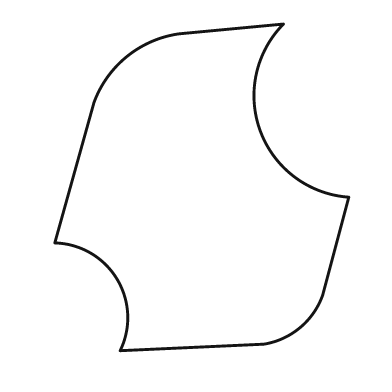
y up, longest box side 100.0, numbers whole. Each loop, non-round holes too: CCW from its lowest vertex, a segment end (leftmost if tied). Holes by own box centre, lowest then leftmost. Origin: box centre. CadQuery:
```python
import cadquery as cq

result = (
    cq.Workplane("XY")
    .moveTo(-25.0, -50.0)
    .lineTo(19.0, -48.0)
    .threePointArc((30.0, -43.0), (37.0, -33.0))
    .lineTo(45.0, -3.0)
    .threePointArc((18.0, 17.0), (25.0, 50.0))
    .lineTo(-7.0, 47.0)
    .threePointArc((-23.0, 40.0), (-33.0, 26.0))
    .lineTo(-45.0, -17.0)
    .threePointArc((-26.0, -28.0), (-25.0, -50.0))
    .close()
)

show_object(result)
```